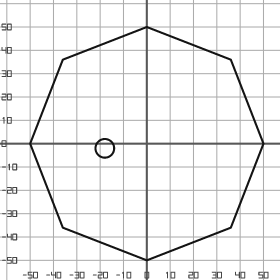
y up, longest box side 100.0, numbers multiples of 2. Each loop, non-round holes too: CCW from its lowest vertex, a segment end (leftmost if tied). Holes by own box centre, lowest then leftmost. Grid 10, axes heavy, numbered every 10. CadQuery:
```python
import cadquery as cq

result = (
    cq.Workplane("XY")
    .moveTo(0.0, -50.0)
    .lineTo(36.0, -36.0)
    .lineTo(50.0, 0.0)
    .lineTo(36.0, 36.0)
    .lineTo(0.0, 50.0)
    .lineTo(-36.0, 36.0)
    .lineTo(-50.0, 0.0)
    .lineTo(-36.0, -36.0)
    .close()
    .moveTo(-18.0, -2.0)
    .circle(4.0)
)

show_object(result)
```